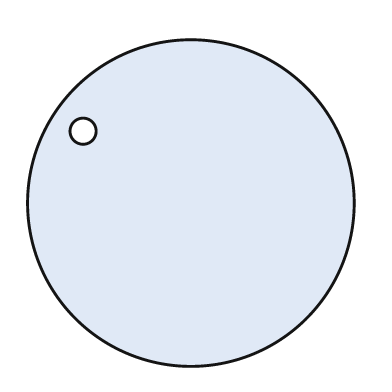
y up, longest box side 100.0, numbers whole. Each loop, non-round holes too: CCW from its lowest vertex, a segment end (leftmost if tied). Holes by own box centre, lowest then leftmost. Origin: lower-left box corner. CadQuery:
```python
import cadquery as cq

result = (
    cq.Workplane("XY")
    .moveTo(50.0, 50.0)
    .circle(50.0)
    .moveTo(17.0, 72.0)
    .circle(4.0)
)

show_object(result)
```